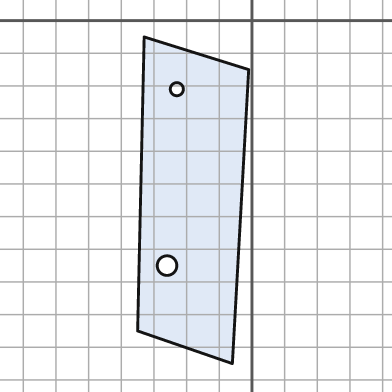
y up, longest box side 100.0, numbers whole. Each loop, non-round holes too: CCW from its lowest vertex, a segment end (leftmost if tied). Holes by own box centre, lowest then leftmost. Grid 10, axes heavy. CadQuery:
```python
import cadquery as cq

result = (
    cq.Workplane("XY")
    .moveTo(-6.0, -105.0)
    .lineTo(-1.0, -15.0)
    .lineTo(-33.0, -5.0)
    .lineTo(-35.0, -95.0)
    .close()
    .moveTo(-26.0, -75.0)
    .circle(3.0)
    .moveTo(-23.0, -21.0)
    .circle(2.0)
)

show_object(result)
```